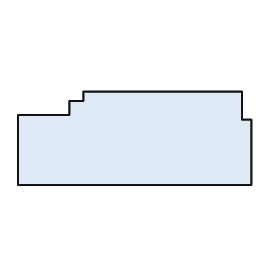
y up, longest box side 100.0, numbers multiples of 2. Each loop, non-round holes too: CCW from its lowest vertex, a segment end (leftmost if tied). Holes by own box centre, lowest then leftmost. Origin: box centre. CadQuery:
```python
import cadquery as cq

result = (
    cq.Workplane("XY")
    .moveTo(-50.0, -20.0)
    .lineTo(50.0, -20.0)
    .lineTo(50.0, 8.0)
    .lineTo(46.0, 8.0)
    .lineTo(46.0, 20.0)
    .lineTo(-22.0, 20.0)
    .lineTo(-22.0, 16.0)
    .lineTo(-28.0, 16.0)
    .lineTo(-28.0, 10.0)
    .lineTo(-50.0, 10.0)
    .close()
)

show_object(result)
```